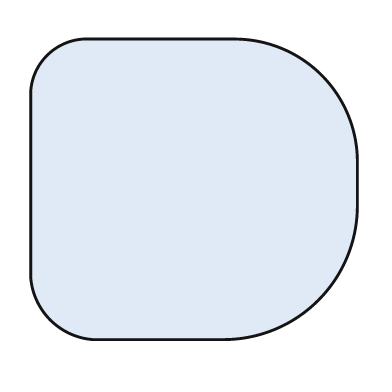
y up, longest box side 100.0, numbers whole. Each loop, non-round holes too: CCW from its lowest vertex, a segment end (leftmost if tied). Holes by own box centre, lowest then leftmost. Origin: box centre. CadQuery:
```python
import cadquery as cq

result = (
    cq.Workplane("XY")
    .moveTo(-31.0, -46.0)
    .lineTo(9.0, -46.0)
    .threePointArc((38.0, -34.0), (50.0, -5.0))
    .lineTo(50.0, 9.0)
    .threePointArc((39.0, 35.0), (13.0, 46.0))
    .lineTo(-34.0, 46.0)
    .threePointArc((-45.0, 41.0), (-50.0, 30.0))
    .lineTo(-50.0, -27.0)
    .threePointArc((-44.0, -40.0), (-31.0, -46.0))
    .close()
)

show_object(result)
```